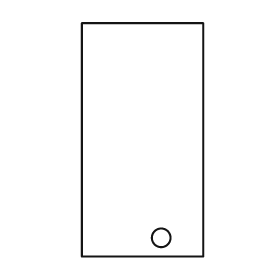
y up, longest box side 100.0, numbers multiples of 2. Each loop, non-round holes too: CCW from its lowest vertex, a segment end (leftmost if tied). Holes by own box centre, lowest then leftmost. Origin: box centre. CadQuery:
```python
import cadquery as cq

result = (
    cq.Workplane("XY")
    .moveTo(-26.0, -50.0)
    .lineTo(26.0, -50.0)
    .lineTo(26.0, 50.0)
    .lineTo(-26.0, 50.0)
    .close()
    .moveTo(8.0, -42.0)
    .circle(4.0)
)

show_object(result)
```